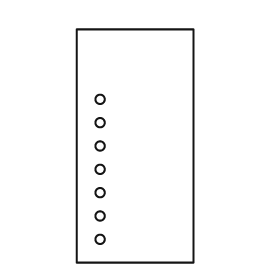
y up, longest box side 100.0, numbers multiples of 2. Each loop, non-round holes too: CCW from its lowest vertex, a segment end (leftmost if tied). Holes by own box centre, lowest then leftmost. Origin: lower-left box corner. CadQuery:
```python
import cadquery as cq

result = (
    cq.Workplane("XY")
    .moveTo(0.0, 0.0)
    .lineTo(50.0, 0.0)
    .lineTo(50.0, 100.0)
    .lineTo(0.0, 100.0)
    .close()
    .moveTo(10.0, 10.0)
    .circle(2.0)
    .moveTo(10.0, 20.0)
    .circle(2.0)
    .moveTo(10.0, 30.0)
    .circle(2.0)
    .moveTo(10.0, 40.0)
    .circle(2.0)
    .moveTo(10.0, 50.0)
    .circle(2.0)
    .moveTo(10.0, 60.0)
    .circle(2.0)
    .moveTo(10.0, 70.0)
    .circle(2.0)
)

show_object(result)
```